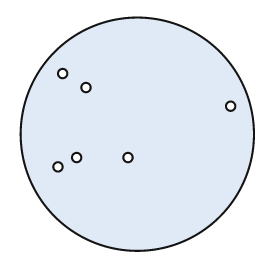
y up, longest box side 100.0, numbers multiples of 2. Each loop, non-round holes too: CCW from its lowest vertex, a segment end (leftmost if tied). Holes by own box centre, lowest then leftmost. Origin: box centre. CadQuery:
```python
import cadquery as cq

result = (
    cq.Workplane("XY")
    .moveTo(0.0, 0.0)
    .circle(50.0)
    .moveTo(-34.0, -14.0)
    .circle(2.0)
    .moveTo(-26.0, -10.0)
    .circle(2.0)
    .moveTo(-4.0, -10.0)
    .circle(2.0)
    .moveTo(40.0, 12.0)
    .circle(2.0)
    .moveTo(-22.0, 20.0)
    .circle(2.0)
    .moveTo(-32.0, 26.0)
    .circle(2.0)
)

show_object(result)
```